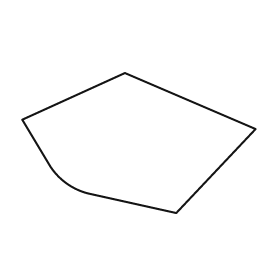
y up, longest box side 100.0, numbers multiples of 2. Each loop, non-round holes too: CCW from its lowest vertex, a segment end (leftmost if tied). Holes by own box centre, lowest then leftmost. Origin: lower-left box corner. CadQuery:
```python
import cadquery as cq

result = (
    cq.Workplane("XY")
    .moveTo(66.0, 0.0)
    .lineTo(100.0, 36.0)
    .lineTo(44.0, 60.0)
    .lineTo(0.0, 40.0)
    .lineTo(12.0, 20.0)
    .threePointArc((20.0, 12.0), (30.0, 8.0))
    .close()
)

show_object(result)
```